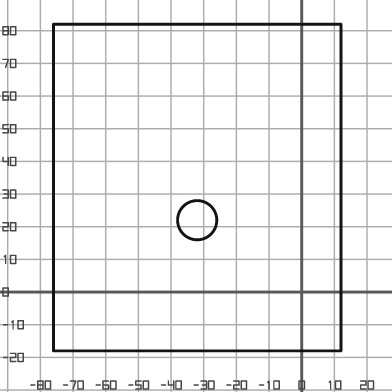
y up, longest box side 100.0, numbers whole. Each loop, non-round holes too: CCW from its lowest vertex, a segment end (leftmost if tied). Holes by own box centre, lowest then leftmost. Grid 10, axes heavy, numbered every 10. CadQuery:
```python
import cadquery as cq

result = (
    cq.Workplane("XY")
    .moveTo(-76.0, -18.0)
    .lineTo(12.0, -18.0)
    .lineTo(12.0, 82.0)
    .lineTo(-76.0, 82.0)
    .close()
    .moveTo(-32.0, 22.0)
    .circle(6.0)
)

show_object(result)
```